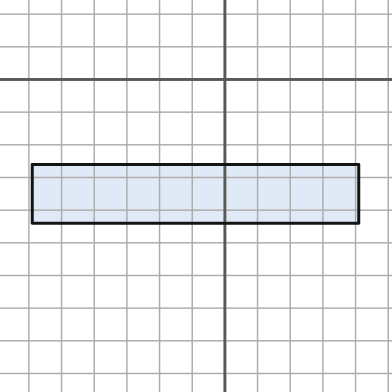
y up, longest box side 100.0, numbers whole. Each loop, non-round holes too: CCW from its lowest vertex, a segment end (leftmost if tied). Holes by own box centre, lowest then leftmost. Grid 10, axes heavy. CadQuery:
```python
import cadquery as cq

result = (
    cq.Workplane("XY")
    .moveTo(-59.0, -44.0)
    .lineTo(41.0, -44.0)
    .lineTo(41.0, -26.0)
    .lineTo(-59.0, -26.0)
    .close()
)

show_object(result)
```